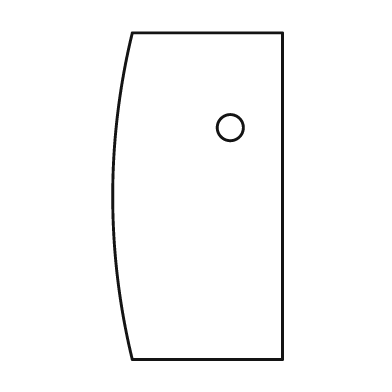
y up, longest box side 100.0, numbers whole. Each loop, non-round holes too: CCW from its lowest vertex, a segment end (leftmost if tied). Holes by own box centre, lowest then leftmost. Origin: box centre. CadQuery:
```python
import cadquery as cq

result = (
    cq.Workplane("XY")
    .moveTo(-20.0, -50.0)
    .lineTo(26.0, -50.0)
    .lineTo(26.0, 50.0)
    .lineTo(-20.0, 50.0)
    .threePointArc((-26.0, 0.0), (-20.0, -50.0))
    .close()
    .moveTo(10.0, 21.0)
    .circle(4.0)
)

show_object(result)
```